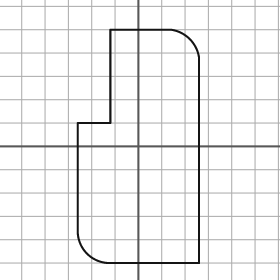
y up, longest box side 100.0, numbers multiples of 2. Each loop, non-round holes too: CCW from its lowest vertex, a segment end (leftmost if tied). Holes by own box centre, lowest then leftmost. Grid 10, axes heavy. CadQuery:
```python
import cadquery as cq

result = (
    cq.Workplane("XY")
    .moveTo(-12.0, -50.0)
    .lineTo(26.0, -50.0)
    .lineTo(26.0, 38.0)
    .threePointArc((22.0, 46.0), (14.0, 50.0))
    .lineTo(-12.0, 50.0)
    .lineTo(-12.0, 10.0)
    .lineTo(-26.0, 10.0)
    .lineTo(-26.0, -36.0)
    .threePointArc((-22.0, -46.0), (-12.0, -50.0))
    .close()
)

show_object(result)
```